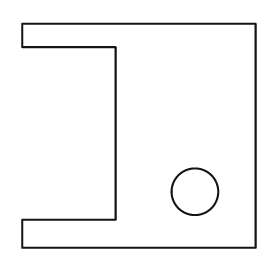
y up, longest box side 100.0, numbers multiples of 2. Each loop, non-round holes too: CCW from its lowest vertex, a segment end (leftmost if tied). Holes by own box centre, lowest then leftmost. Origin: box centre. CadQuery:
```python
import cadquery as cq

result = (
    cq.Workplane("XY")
    .moveTo(-50.0, -48.0)
    .lineTo(50.0, -48.0)
    .lineTo(50.0, 48.0)
    .lineTo(-50.0, 48.0)
    .lineTo(-50.0, 38.0)
    .lineTo(-10.0, 38.0)
    .lineTo(-10.0, -36.0)
    .lineTo(-50.0, -36.0)
    .close()
    .moveTo(24.0, -24.0)
    .circle(10.0)
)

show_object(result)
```